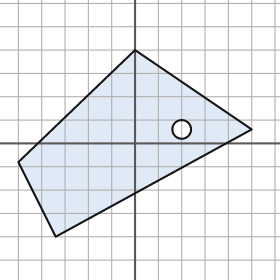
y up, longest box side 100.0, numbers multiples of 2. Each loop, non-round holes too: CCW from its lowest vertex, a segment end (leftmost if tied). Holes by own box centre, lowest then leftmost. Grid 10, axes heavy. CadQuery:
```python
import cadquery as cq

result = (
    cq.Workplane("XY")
    .moveTo(-34.0, -40.0)
    .lineTo(50.0, 6.0)
    .lineTo(0.0, 40.0)
    .lineTo(-50.0, -8.0)
    .close()
    .moveTo(20.0, 6.0)
    .circle(4.0)
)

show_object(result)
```